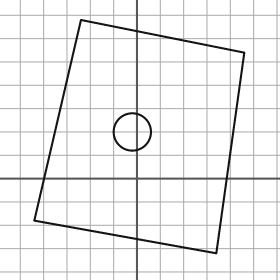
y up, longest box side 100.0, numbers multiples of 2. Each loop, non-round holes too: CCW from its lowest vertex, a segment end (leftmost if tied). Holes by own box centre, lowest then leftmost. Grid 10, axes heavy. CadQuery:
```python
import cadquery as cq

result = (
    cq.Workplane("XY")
    .moveTo(34.0, -32.0)
    .lineTo(46.0, 54.0)
    .lineTo(-24.0, 68.0)
    .lineTo(-44.0, -18.0)
    .close()
    .moveTo(-2.0, 20.0)
    .circle(8.0)
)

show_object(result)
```